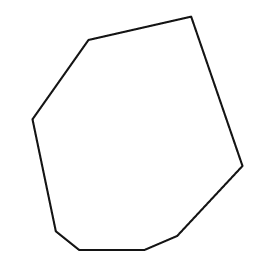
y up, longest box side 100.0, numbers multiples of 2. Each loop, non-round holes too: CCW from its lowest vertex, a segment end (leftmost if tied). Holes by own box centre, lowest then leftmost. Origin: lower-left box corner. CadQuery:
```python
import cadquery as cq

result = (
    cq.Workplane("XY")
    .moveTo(20.0, 0.0)
    .lineTo(48.0, 0.0)
    .lineTo(62.0, 6.0)
    .lineTo(90.0, 36.0)
    .lineTo(68.0, 100.0)
    .lineTo(24.0, 90.0)
    .lineTo(0.0, 56.0)
    .lineTo(10.0, 8.0)
    .close()
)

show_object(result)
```